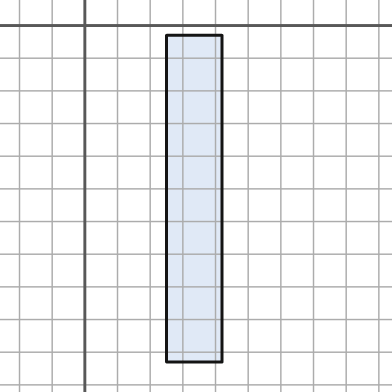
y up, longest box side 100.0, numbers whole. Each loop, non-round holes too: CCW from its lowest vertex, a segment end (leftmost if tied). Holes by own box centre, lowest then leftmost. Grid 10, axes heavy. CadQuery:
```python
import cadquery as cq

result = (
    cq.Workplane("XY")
    .moveTo(25.0, -103.0)
    .lineTo(42.0, -103.0)
    .lineTo(42.0, -3.0)
    .lineTo(25.0, -3.0)
    .close()
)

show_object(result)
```